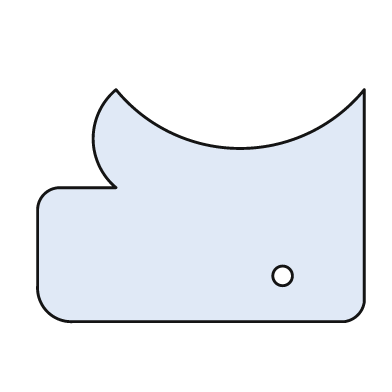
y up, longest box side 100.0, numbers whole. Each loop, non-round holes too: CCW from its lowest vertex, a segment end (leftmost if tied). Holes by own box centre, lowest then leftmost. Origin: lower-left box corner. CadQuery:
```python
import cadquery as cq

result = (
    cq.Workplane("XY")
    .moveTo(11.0, 0.0)
    .lineTo(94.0, 0.0)
    .threePointArc((98.0, 2.0), (100.0, 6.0))
    .lineTo(100.0, 71.0)
    .threePointArc((62.0, 53.0), (24.0, 71.0))
    .threePointArc((17.0, 56.0), (24.0, 41.0))
    .lineTo(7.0, 41.0)
    .threePointArc((2.0, 39.0), (0.0, 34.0))
    .lineTo(0.0, 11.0)
    .threePointArc((3.0, 3.0), (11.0, 0.0))
    .close()
    .moveTo(75.0, 14.0)
    .circle(3.0)
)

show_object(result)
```